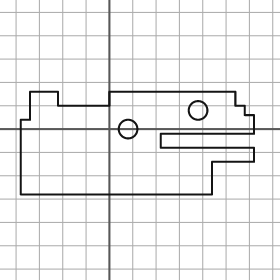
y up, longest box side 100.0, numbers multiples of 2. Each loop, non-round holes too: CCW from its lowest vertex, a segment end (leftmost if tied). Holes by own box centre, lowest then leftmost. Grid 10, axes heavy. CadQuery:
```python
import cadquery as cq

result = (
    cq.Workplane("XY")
    .moveTo(-38.0, -28.0)
    .lineTo(44.0, -28.0)
    .lineTo(44.0, -14.0)
    .lineTo(62.0, -14.0)
    .lineTo(62.0, -8.0)
    .lineTo(22.0, -8.0)
    .lineTo(22.0, -2.0)
    .lineTo(62.0, -2.0)
    .lineTo(62.0, 6.0)
    .lineTo(58.0, 6.0)
    .lineTo(58.0, 10.0)
    .lineTo(54.0, 10.0)
    .lineTo(54.0, 16.0)
    .lineTo(0.0, 16.0)
    .lineTo(0.0, 10.0)
    .lineTo(-22.0, 10.0)
    .lineTo(-22.0, 16.0)
    .lineTo(-34.0, 16.0)
    .lineTo(-34.0, 4.0)
    .lineTo(-38.0, 4.0)
    .close()
    .moveTo(8.0, 0.0)
    .circle(4.0)
    .moveTo(38.0, 8.0)
    .circle(4.0)
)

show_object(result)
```